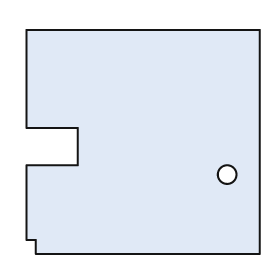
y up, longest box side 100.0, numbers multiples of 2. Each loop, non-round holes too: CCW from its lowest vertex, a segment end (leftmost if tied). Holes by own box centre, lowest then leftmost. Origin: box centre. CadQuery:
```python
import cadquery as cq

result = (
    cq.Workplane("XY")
    .moveTo(-46.0, -48.0)
    .lineTo(50.0, -48.0)
    .lineTo(50.0, 48.0)
    .lineTo(-50.0, 48.0)
    .lineTo(-50.0, 6.0)
    .lineTo(-28.0, 6.0)
    .lineTo(-28.0, -10.0)
    .lineTo(-50.0, -10.0)
    .lineTo(-50.0, -42.0)
    .lineTo(-46.0, -42.0)
    .close()
    .moveTo(36.0, -14.0)
    .circle(4.0)
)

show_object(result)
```